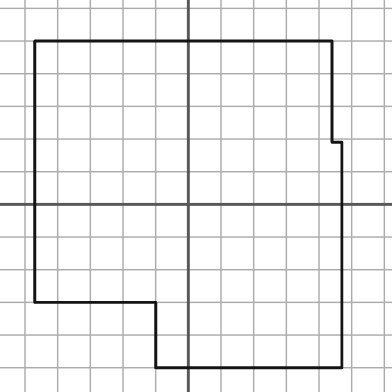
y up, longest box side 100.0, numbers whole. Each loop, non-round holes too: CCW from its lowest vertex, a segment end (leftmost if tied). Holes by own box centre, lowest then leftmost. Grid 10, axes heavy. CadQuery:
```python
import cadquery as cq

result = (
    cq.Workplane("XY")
    .moveTo(-10.0, -50.0)
    .lineTo(47.0, -50.0)
    .lineTo(47.0, 19.0)
    .lineTo(44.0, 19.0)
    .lineTo(44.0, 50.0)
    .lineTo(-47.0, 50.0)
    .lineTo(-47.0, -30.0)
    .lineTo(-10.0, -30.0)
    .close()
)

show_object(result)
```